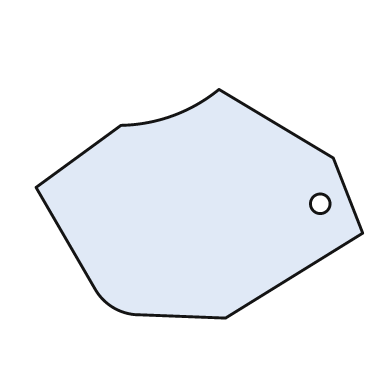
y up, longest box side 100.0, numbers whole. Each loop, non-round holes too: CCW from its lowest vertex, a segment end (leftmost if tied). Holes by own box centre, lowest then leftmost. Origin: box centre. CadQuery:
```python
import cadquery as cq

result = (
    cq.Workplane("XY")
    .moveTo(8.0, -35.0)
    .lineTo(50.0, -9.0)
    .lineTo(41.0, 14.0)
    .lineTo(6.0, 35.0)
    .threePointArc((-8.0, 27.0), (-24.0, 24.0))
    .lineTo(-50.0, 5.0)
    .lineTo(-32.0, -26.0)
    .threePointArc((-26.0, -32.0), (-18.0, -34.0))
    .close()
    .moveTo(37.0, 0.0)
    .circle(3.0)
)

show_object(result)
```